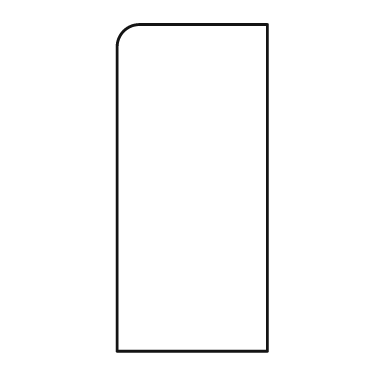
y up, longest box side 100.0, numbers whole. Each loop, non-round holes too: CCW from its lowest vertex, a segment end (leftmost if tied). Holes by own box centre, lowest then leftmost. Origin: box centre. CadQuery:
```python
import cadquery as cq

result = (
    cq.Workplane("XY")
    .moveTo(-23.0, -50.0)
    .lineTo(23.0, -50.0)
    .lineTo(23.0, 50.0)
    .lineTo(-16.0, 50.0)
    .threePointArc((-21.0, 48.0), (-23.0, 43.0))
    .close()
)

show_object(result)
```